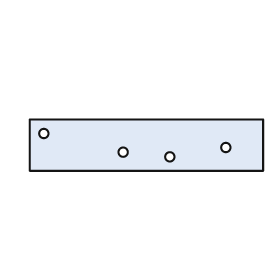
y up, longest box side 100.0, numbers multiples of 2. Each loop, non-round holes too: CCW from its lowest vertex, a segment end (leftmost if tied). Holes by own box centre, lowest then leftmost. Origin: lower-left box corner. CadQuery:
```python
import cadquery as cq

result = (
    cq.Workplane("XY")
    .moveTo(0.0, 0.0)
    .lineTo(100.0, 0.0)
    .lineTo(100.0, 22.0)
    .lineTo(0.0, 22.0)
    .close()
    .moveTo(60.0, 6.0)
    .circle(2.0)
    .moveTo(40.0, 8.0)
    .circle(2.0)
    .moveTo(84.0, 10.0)
    .circle(2.0)
    .moveTo(6.0, 16.0)
    .circle(2.0)
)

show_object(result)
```